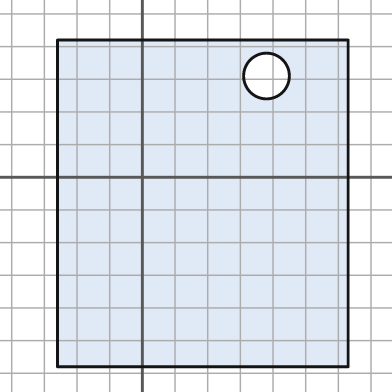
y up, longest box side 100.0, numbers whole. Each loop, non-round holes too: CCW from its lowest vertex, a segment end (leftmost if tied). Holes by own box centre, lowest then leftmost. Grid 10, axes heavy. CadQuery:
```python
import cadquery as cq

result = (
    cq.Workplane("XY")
    .moveTo(-26.0, -58.0)
    .lineTo(63.0, -58.0)
    .lineTo(63.0, 42.0)
    .lineTo(-26.0, 42.0)
    .close()
    .moveTo(38.0, 31.0)
    .circle(7.0)
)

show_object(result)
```